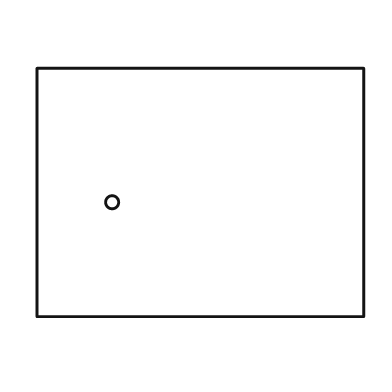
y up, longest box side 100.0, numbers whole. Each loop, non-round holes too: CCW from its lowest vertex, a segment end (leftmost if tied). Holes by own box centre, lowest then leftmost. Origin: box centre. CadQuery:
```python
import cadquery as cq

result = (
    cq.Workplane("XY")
    .moveTo(-50.0, -38.0)
    .lineTo(50.0, -38.0)
    .lineTo(50.0, 38.0)
    .lineTo(-50.0, 38.0)
    .close()
    .moveTo(-27.0, -3.0)
    .circle(2.0)
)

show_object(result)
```